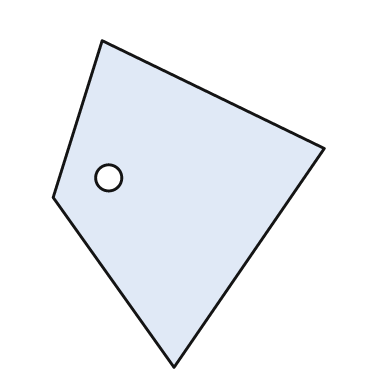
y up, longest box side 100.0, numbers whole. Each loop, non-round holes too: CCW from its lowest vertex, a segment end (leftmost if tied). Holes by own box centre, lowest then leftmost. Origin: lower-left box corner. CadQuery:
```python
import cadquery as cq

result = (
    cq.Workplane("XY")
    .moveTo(37.0, 0.0)
    .lineTo(83.0, 67.0)
    .lineTo(15.0, 100.0)
    .lineTo(0.0, 52.0)
    .close()
    .moveTo(17.0, 58.0)
    .circle(4.0)
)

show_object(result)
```